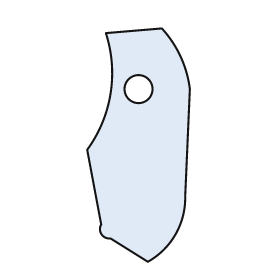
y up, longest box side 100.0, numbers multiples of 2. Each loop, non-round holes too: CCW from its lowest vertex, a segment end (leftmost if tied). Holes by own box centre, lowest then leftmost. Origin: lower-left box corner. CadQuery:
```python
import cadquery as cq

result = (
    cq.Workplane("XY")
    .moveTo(26.0, 0.0)
    .threePointArc((38.0, 12.0), (42.0, 28.0))
    .lineTo(44.0, 74.0)
    .threePointArc((40.0, 88.0), (32.0, 100.0))
    .lineTo(8.0, 98.0)
    .threePointArc((10.0, 72.0), (0.0, 48.0))
    .lineTo(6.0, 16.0)
    .threePointArc((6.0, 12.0), (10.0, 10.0))
    .close()
    .moveTo(22.0, 74.0)
    .circle(6.0)
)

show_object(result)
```